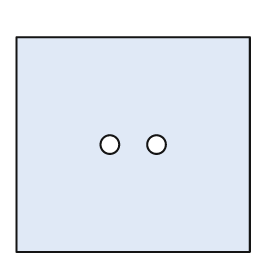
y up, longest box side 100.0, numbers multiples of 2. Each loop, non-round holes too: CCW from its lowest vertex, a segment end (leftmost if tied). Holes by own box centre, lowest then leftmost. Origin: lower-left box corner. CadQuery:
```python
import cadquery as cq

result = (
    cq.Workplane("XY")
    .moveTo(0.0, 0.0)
    .lineTo(100.0, 0.0)
    .lineTo(100.0, 92.0)
    .lineTo(0.0, 92.0)
    .close()
    .moveTo(40.0, 46.0)
    .circle(4.0)
    .moveTo(60.0, 46.0)
    .circle(4.0)
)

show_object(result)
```